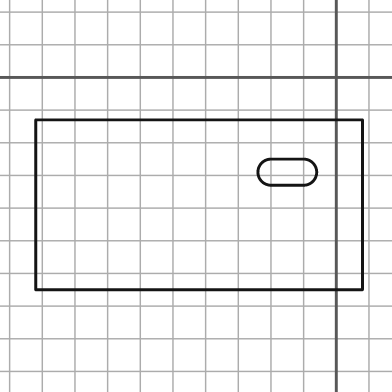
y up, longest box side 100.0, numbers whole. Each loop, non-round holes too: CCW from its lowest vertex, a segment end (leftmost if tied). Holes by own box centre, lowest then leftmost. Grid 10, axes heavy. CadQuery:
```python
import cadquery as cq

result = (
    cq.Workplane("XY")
    .moveTo(-92.0, -65.0)
    .lineTo(8.0, -65.0)
    .lineTo(8.0, -13.0)
    .lineTo(-92.0, -13.0)
    .close()
    .moveTo(-20.0, -33.0)
    .lineTo(-10.0, -33.0)
    .threePointArc((-6.0, -29.0), (-10.0, -25.0))
    .lineTo(-20.0, -25.0)
    .threePointArc((-24.0, -29.0), (-20.0, -33.0))
    .close()
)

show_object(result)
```